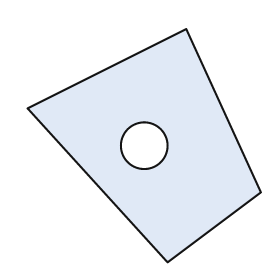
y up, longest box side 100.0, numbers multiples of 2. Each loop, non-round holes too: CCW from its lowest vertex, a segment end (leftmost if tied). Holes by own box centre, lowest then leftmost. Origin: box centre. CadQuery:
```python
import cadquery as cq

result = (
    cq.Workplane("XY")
    .moveTo(10.0, -50.0)
    .lineTo(50.0, -20.0)
    .lineTo(18.0, 50.0)
    .lineTo(-50.0, 16.0)
    .close()
    .moveTo(0.0, 0.0)
    .circle(10.0)
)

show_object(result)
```